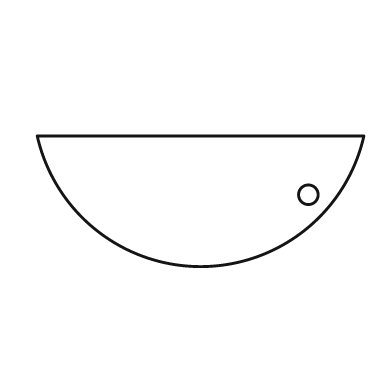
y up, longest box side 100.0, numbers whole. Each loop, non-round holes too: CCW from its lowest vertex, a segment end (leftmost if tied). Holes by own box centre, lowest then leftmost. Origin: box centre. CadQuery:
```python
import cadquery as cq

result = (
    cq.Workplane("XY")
    .moveTo(-50.0, 20.0)
    .threePointArc((0.0, -20.0), (50.0, 20.0))
    .close()
    .moveTo(33.0, 2.0)
    .circle(3.0)
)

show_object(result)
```